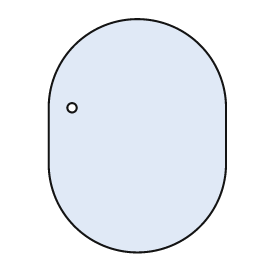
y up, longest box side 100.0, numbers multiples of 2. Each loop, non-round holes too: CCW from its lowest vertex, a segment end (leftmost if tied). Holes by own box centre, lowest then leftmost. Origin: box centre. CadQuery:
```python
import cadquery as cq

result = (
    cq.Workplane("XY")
    .moveTo(-38.0, -12.0)
    .threePointArc((0.0, -50.0), (38.0, -12.0))
    .lineTo(38.0, 12.0)
    .threePointArc((0.0, 50.0), (-38.0, 12.0))
    .close()
    .moveTo(-28.0, 12.0)
    .circle(2.0)
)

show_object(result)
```